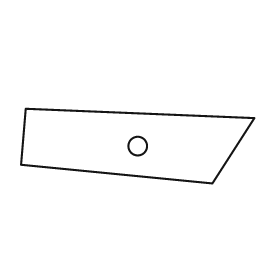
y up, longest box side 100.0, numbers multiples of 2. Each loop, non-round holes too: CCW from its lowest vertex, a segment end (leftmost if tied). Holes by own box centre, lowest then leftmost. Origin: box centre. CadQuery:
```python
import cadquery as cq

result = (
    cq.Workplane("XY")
    .moveTo(32.0, -16.0)
    .lineTo(50.0, 12.0)
    .lineTo(-48.0, 16.0)
    .lineTo(-50.0, -8.0)
    .close()
    .moveTo(0.0, 0.0)
    .circle(4.0)
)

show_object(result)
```